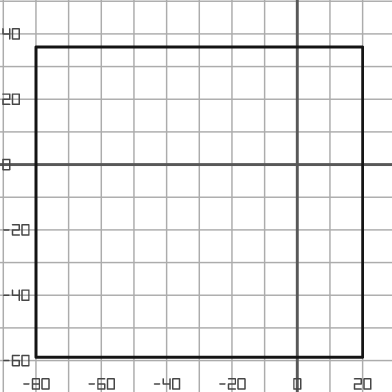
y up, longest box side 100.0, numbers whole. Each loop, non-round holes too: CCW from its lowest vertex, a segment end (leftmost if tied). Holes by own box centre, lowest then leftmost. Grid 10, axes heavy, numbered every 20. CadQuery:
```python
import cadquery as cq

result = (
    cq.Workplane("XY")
    .moveTo(-80.0, -59.0)
    .lineTo(20.0, -59.0)
    .lineTo(20.0, 36.0)
    .lineTo(-80.0, 36.0)
    .close()
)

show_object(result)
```